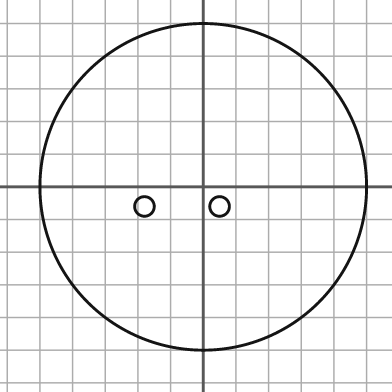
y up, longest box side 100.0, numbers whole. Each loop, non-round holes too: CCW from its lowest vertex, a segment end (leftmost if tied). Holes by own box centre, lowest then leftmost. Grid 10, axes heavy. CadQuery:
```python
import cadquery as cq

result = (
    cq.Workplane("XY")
    .moveTo(0.0, 0.0)
    .circle(50.0)
    .moveTo(-18.0, -6.0)
    .circle(3.0)
    .moveTo(5.0, -6.0)
    .circle(3.0)
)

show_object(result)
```